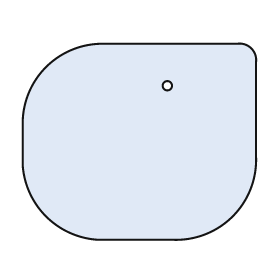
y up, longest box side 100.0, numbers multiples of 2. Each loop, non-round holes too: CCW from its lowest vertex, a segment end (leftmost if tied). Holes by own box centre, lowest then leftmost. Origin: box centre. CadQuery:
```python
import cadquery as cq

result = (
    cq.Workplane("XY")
    .moveTo(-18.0, -42.0)
    .lineTo(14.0, -42.0)
    .threePointArc((40.0, -32.0), (50.0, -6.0))
    .lineTo(50.0, 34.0)
    .threePointArc((48.0, 40.0), (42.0, 42.0))
    .lineTo(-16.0, 42.0)
    .threePointArc((-40.0, 32.0), (-50.0, 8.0))
    .lineTo(-50.0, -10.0)
    .threePointArc((-40.0, -32.0), (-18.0, -42.0))
    .close()
    .moveTo(12.0, 24.0)
    .circle(2.0)
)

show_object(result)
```